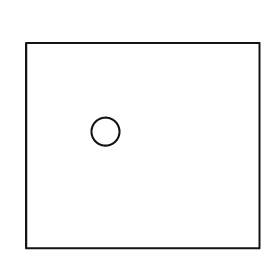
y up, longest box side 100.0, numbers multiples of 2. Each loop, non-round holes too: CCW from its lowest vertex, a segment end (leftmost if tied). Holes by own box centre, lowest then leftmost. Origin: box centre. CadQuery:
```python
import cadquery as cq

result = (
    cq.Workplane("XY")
    .moveTo(-50.0, -44.0)
    .lineTo(50.0, -44.0)
    .lineTo(50.0, 44.0)
    .lineTo(-50.0, 44.0)
    .close()
    .moveTo(-16.0, 6.0)
    .circle(6.0)
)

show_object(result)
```